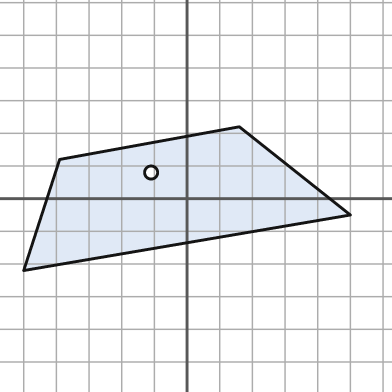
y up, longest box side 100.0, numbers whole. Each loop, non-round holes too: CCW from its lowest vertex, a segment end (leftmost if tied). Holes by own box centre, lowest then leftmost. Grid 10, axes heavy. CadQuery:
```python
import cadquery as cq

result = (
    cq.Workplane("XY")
    .moveTo(-50.0, -22.0)
    .lineTo(50.0, -5.0)
    .lineTo(16.0, 22.0)
    .lineTo(-39.0, 12.0)
    .close()
    .moveTo(-11.0, 8.0)
    .circle(2.0)
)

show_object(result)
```